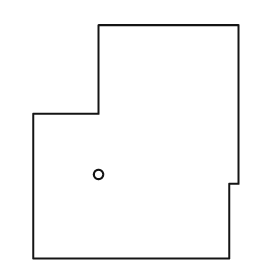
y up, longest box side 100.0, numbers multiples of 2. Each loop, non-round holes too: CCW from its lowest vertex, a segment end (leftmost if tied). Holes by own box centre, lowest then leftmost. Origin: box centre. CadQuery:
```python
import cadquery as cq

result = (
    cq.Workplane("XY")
    .moveTo(-44.0, -50.0)
    .lineTo(40.0, -50.0)
    .lineTo(40.0, -18.0)
    .lineTo(44.0, -18.0)
    .lineTo(44.0, 50.0)
    .lineTo(-16.0, 50.0)
    .lineTo(-16.0, 12.0)
    .lineTo(-44.0, 12.0)
    .close()
    .moveTo(-16.0, -14.0)
    .circle(2.0)
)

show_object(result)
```